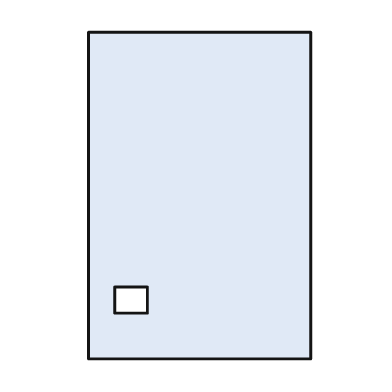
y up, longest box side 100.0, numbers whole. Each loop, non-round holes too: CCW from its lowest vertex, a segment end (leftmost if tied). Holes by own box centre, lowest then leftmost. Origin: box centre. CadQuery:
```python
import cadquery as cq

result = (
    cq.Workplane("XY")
    .moveTo(-34.0, -50.0)
    .lineTo(34.0, -50.0)
    .lineTo(34.0, 50.0)
    .lineTo(-34.0, 50.0)
    .close()
    .moveTo(-26.0, -36.0)
    .lineTo(-16.0, -36.0)
    .lineTo(-16.0, -28.0)
    .lineTo(-26.0, -28.0)
    .close()
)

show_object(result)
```